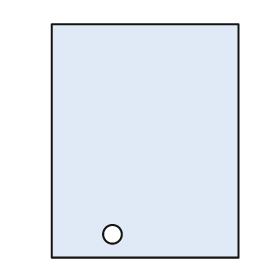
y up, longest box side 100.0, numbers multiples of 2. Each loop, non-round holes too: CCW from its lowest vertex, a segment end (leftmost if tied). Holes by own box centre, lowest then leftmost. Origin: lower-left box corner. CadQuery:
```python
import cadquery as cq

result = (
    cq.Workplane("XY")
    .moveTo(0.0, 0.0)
    .lineTo(80.0, 0.0)
    .lineTo(80.0, 100.0)
    .lineTo(0.0, 100.0)
    .close()
    .moveTo(26.0, 10.0)
    .circle(4.0)
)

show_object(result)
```